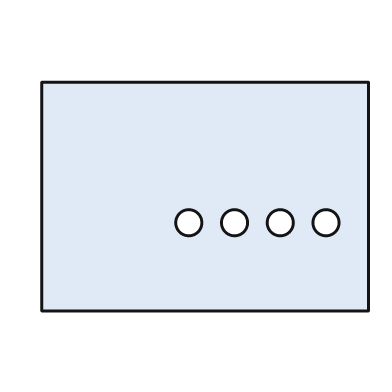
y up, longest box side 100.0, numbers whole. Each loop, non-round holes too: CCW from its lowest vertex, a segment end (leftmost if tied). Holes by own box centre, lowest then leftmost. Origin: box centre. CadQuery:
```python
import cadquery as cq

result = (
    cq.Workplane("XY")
    .moveTo(-50.0, -35.0)
    .lineTo(50.0, -35.0)
    .lineTo(50.0, 35.0)
    .lineTo(-50.0, 35.0)
    .close()
    .moveTo(-5.0, -8.0)
    .circle(4.0)
    .moveTo(9.0, -8.0)
    .circle(4.0)
    .moveTo(23.0, -8.0)
    .circle(4.0)
    .moveTo(37.0, -8.0)
    .circle(4.0)
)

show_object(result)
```